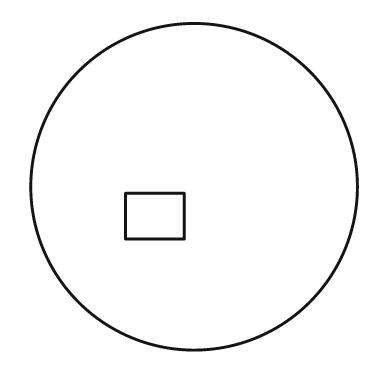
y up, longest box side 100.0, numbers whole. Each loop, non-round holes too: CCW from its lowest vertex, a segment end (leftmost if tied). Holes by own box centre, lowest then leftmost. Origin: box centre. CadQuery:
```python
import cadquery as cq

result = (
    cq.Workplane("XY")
    .moveTo(0.0, 0.0)
    .circle(50.0)
    .moveTo(-21.0, -16.0)
    .lineTo(-3.0, -16.0)
    .lineTo(-3.0, -2.0)
    .lineTo(-21.0, -2.0)
    .close()
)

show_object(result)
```